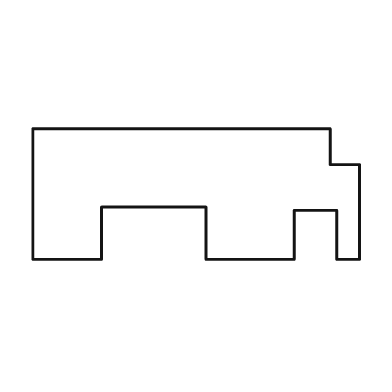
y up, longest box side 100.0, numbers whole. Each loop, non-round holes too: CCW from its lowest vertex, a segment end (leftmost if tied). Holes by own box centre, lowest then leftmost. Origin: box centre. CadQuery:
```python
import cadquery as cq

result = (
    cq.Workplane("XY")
    .moveTo(-50.0, -20.0)
    .lineTo(-29.0, -20.0)
    .lineTo(-29.0, -4.0)
    .lineTo(3.0, -4.0)
    .lineTo(3.0, -20.0)
    .lineTo(30.0, -20.0)
    .lineTo(30.0, -5.0)
    .lineTo(43.0, -5.0)
    .lineTo(43.0, -20.0)
    .lineTo(50.0, -20.0)
    .lineTo(50.0, 9.0)
    .lineTo(41.0, 9.0)
    .lineTo(41.0, 20.0)
    .lineTo(-50.0, 20.0)
    .close()
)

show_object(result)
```